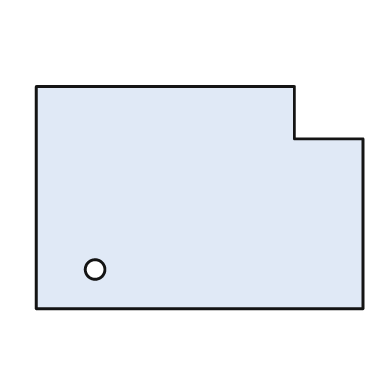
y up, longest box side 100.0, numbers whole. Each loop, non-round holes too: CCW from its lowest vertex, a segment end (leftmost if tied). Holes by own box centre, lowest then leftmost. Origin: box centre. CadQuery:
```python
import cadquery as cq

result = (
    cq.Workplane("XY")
    .moveTo(-50.0, -34.0)
    .lineTo(50.0, -34.0)
    .lineTo(50.0, 18.0)
    .lineTo(29.0, 18.0)
    .lineTo(29.0, 34.0)
    .lineTo(-50.0, 34.0)
    .close()
    .moveTo(-32.0, -22.0)
    .circle(3.0)
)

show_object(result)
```